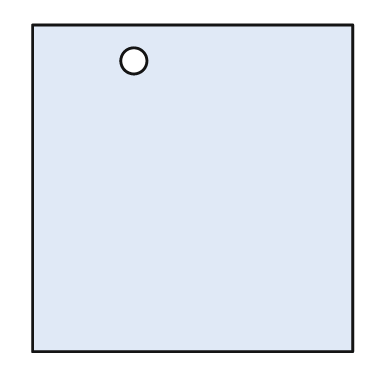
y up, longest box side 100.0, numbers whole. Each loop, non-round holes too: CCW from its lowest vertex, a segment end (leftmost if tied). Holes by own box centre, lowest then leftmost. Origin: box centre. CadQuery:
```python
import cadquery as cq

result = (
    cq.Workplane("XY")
    .moveTo(-49.0, -50.0)
    .lineTo(49.0, -50.0)
    .lineTo(49.0, 50.0)
    .lineTo(-49.0, 50.0)
    .close()
    .moveTo(-18.0, 39.0)
    .circle(4.0)
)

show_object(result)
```